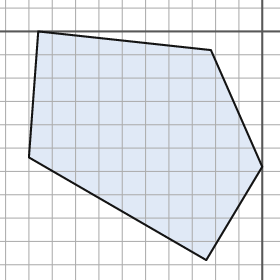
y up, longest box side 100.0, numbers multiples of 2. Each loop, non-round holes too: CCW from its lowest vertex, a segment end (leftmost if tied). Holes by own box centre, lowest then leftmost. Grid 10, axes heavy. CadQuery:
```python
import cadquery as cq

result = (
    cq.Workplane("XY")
    .moveTo(-24.0, -98.0)
    .lineTo(0.0, -58.0)
    .lineTo(-22.0, -8.0)
    .lineTo(-96.0, 0.0)
    .lineTo(-100.0, -54.0)
    .close()
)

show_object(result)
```